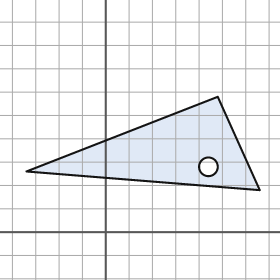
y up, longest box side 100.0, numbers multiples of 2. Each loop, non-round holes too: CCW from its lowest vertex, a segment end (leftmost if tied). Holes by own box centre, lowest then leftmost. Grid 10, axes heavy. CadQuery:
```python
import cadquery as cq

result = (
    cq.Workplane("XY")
    .moveTo(66.0, 18.0)
    .lineTo(48.0, 58.0)
    .lineTo(-34.0, 26.0)
    .close()
    .moveTo(44.0, 28.0)
    .circle(4.0)
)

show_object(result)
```